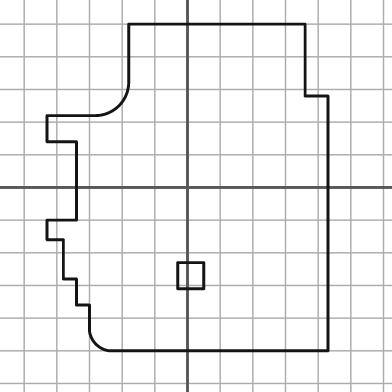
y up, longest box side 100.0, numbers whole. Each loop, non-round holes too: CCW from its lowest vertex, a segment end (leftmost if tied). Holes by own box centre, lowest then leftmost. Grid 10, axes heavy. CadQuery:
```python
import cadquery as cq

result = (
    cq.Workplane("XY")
    .moveTo(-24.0, -50.0)
    .lineTo(43.0, -50.0)
    .lineTo(43.0, 28.0)
    .lineTo(36.0, 28.0)
    .lineTo(36.0, 50.0)
    .lineTo(-18.0, 50.0)
    .lineTo(-18.0, 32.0)
    .threePointArc((-21.0, 25.0), (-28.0, 22.0))
    .lineTo(-43.0, 22.0)
    .lineTo(-43.0, 14.0)
    .lineTo(-34.0, 14.0)
    .lineTo(-34.0, -10.0)
    .lineTo(-43.0, -10.0)
    .lineTo(-43.0, -16.0)
    .lineTo(-38.0, -16.0)
    .lineTo(-38.0, -28.0)
    .lineTo(-34.0, -28.0)
    .lineTo(-34.0, -36.0)
    .lineTo(-30.0, -36.0)
    .lineTo(-30.0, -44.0)
    .threePointArc((-28.0, -48.0), (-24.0, -50.0))
    .close()
    .moveTo(-3.0, -31.0)
    .lineTo(5.0, -31.0)
    .lineTo(5.0, -23.0)
    .lineTo(-3.0, -23.0)
    .close()
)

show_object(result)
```